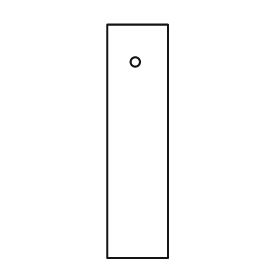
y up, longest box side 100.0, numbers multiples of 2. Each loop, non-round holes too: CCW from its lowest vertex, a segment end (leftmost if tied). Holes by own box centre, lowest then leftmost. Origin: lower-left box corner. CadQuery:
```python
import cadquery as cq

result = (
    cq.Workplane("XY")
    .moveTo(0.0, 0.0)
    .lineTo(26.0, 0.0)
    .lineTo(26.0, 100.0)
    .lineTo(0.0, 100.0)
    .close()
    .moveTo(12.0, 84.0)
    .circle(2.0)
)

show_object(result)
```